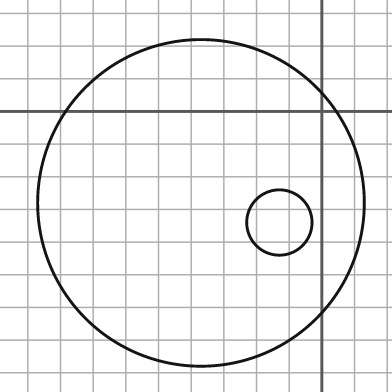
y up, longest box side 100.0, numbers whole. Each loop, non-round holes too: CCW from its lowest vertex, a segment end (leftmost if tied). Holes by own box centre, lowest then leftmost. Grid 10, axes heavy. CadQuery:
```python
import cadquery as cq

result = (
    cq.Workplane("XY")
    .moveTo(-37.0, -28.0)
    .circle(50.0)
    .moveTo(-13.0, -34.0)
    .circle(10.0)
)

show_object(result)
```